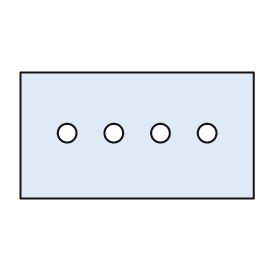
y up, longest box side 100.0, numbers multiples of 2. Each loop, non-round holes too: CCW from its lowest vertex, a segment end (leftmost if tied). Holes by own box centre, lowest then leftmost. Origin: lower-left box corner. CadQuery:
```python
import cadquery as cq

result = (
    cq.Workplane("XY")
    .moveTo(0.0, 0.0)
    .lineTo(100.0, 0.0)
    .lineTo(100.0, 54.0)
    .lineTo(0.0, 54.0)
    .close()
    .moveTo(20.0, 28.0)
    .circle(4.0)
    .moveTo(40.0, 28.0)
    .circle(4.0)
    .moveTo(60.0, 28.0)
    .circle(4.0)
    .moveTo(80.0, 28.0)
    .circle(4.0)
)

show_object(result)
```